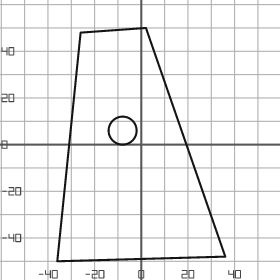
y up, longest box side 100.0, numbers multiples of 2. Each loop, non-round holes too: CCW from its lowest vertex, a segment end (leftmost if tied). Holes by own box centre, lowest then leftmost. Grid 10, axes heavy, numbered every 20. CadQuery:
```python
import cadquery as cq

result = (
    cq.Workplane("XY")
    .moveTo(-36.0, -50.0)
    .lineTo(36.0, -48.0)
    .lineTo(2.0, 50.0)
    .lineTo(-26.0, 48.0)
    .close()
    .moveTo(-8.0, 6.0)
    .circle(6.0)
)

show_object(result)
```